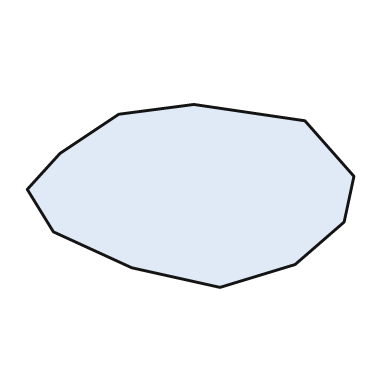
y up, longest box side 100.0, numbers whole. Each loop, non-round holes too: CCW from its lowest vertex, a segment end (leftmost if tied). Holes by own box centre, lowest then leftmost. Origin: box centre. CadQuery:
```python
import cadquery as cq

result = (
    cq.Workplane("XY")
    .moveTo(9.0, -28.0)
    .lineTo(32.0, -21.0)
    .lineTo(47.0, -8.0)
    .lineTo(50.0, 6.0)
    .lineTo(35.0, 23.0)
    .lineTo(1.0, 28.0)
    .lineTo(-22.0, 25.0)
    .lineTo(-40.0, 13.0)
    .lineTo(-50.0, 2.0)
    .lineTo(-42.0, -11.0)
    .lineTo(-18.0, -22.0)
    .close()
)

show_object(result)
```